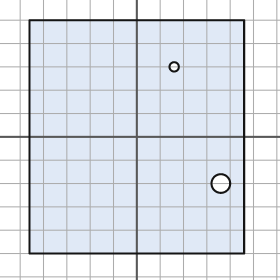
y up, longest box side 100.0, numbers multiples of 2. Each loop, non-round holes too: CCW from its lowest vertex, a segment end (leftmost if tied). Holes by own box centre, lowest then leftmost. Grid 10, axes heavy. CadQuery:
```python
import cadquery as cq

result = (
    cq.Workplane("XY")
    .moveTo(-46.0, -50.0)
    .lineTo(46.0, -50.0)
    .lineTo(46.0, 50.0)
    .lineTo(-46.0, 50.0)
    .close()
    .moveTo(36.0, -20.0)
    .circle(4.0)
    .moveTo(16.0, 30.0)
    .circle(2.0)
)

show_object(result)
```